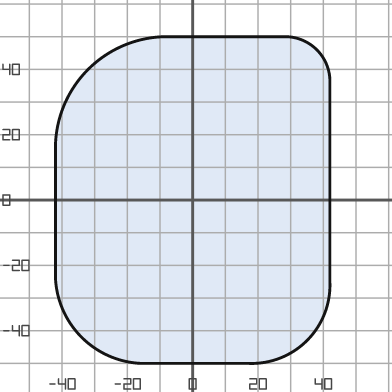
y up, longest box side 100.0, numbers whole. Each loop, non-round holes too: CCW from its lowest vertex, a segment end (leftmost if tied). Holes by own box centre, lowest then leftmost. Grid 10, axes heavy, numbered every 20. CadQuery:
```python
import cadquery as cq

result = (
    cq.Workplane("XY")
    .moveTo(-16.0, -50.0)
    .lineTo(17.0, -50.0)
    .threePointArc((35.0, -43.0), (42.0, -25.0))
    .lineTo(42.0, 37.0)
    .threePointArc((38.0, 46.0), (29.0, 50.0))
    .lineTo(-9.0, 50.0)
    .threePointArc((-32.0, 40.0), (-42.0, 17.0))
    .lineTo(-42.0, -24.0)
    .threePointArc((-34.0, -42.0), (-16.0, -50.0))
    .close()
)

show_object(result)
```